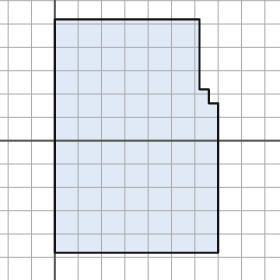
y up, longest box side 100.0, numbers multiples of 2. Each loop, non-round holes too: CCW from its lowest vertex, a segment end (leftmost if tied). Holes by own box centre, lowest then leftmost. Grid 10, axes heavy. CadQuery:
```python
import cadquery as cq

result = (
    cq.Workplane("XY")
    .moveTo(0.0, -48.0)
    .lineTo(70.0, -48.0)
    .lineTo(70.0, 16.0)
    .lineTo(66.0, 16.0)
    .lineTo(66.0, 22.0)
    .lineTo(62.0, 22.0)
    .lineTo(62.0, 52.0)
    .lineTo(0.0, 52.0)
    .close()
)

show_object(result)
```